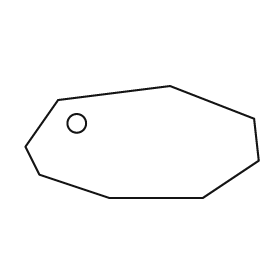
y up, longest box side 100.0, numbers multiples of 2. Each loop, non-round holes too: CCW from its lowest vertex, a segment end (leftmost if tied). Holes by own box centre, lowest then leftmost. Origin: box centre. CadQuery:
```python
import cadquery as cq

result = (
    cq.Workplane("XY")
    .moveTo(-14.0, -24.0)
    .lineTo(26.0, -24.0)
    .lineTo(50.0, -8.0)
    .lineTo(48.0, 10.0)
    .lineTo(12.0, 24.0)
    .lineTo(-36.0, 18.0)
    .lineTo(-50.0, -2.0)
    .lineTo(-44.0, -14.0)
    .close()
    .moveTo(-28.0, 8.0)
    .circle(4.0)
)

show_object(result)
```